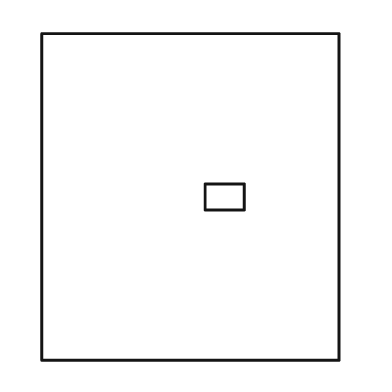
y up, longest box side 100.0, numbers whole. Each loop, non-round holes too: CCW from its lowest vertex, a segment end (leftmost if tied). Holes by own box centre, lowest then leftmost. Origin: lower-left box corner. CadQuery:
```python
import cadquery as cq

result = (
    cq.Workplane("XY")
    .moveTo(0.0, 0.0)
    .lineTo(91.0, 0.0)
    .lineTo(91.0, 100.0)
    .lineTo(0.0, 100.0)
    .close()
    .moveTo(50.0, 46.0)
    .lineTo(62.0, 46.0)
    .lineTo(62.0, 54.0)
    .lineTo(50.0, 54.0)
    .close()
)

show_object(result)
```